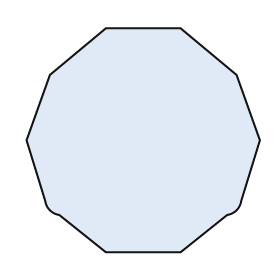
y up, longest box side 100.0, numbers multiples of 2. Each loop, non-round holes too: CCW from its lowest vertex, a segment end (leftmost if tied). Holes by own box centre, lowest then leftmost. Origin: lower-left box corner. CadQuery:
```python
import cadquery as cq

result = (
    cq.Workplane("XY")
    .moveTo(34.0, 0.0)
    .lineTo(66.0, 0.0)
    .lineTo(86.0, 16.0)
    .threePointArc((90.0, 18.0), (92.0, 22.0))
    .lineTo(100.0, 48.0)
    .lineTo(90.0, 76.0)
    .lineTo(66.0, 96.0)
    .lineTo(34.0, 96.0)
    .lineTo(10.0, 76.0)
    .lineTo(0.0, 48.0)
    .lineTo(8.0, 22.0)
    .threePointArc((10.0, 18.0), (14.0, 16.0))
    .close()
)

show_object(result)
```